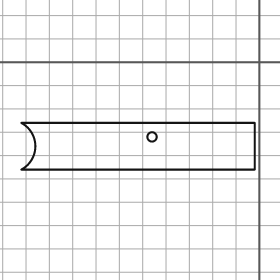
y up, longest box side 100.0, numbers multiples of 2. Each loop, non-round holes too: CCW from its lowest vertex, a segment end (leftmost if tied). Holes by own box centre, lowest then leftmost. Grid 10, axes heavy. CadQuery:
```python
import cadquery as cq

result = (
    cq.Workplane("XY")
    .moveTo(-102.0, -46.0)
    .lineTo(-2.0, -46.0)
    .lineTo(-2.0, -26.0)
    .lineTo(-102.0, -26.0)
    .threePointArc((-96.0, -36.0), (-102.0, -46.0))
    .close()
    .moveTo(-46.0, -32.0)
    .circle(2.0)
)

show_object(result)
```